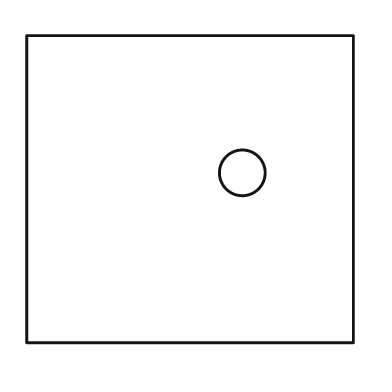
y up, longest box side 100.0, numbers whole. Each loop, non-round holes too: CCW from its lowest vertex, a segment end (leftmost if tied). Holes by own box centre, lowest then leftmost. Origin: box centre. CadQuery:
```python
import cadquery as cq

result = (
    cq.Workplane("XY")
    .moveTo(-50.0, -47.0)
    .lineTo(50.0, -47.0)
    .lineTo(50.0, 47.0)
    .lineTo(-50.0, 47.0)
    .close()
    .moveTo(16.0, 5.0)
    .circle(7.0)
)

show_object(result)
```